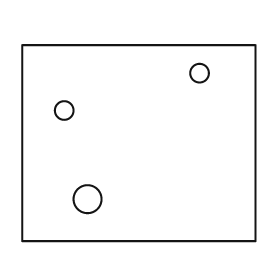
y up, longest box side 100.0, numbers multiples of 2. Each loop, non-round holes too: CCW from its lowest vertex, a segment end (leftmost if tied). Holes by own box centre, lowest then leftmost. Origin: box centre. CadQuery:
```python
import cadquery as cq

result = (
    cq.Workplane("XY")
    .moveTo(-50.0, -42.0)
    .lineTo(50.0, -42.0)
    .lineTo(50.0, 42.0)
    .lineTo(-50.0, 42.0)
    .close()
    .moveTo(-22.0, -24.0)
    .circle(6.0)
    .moveTo(-32.0, 14.0)
    .circle(4.0)
    .moveTo(26.0, 30.0)
    .circle(4.0)
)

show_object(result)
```